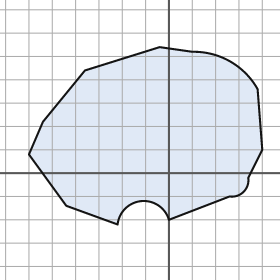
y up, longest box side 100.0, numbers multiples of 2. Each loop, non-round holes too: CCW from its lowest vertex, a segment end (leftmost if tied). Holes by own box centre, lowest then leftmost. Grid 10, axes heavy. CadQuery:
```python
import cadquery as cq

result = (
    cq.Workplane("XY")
    .moveTo(-22.0, -22.0)
    .threePointArc((-12.0, -12.0), (0.0, -20.0))
    .lineTo(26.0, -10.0)
    .threePointArc((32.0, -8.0), (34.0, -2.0))
    .lineTo(40.0, 10.0)
    .lineTo(38.0, 36.0)
    .threePointArc((26.0, 48.0), (10.0, 52.0))
    .lineTo(-4.0, 54.0)
    .lineTo(-36.0, 44.0)
    .lineTo(-54.0, 22.0)
    .lineTo(-60.0, 8.0)
    .lineTo(-44.0, -14.0)
    .close()
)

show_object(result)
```